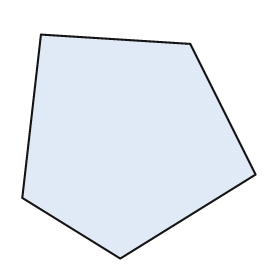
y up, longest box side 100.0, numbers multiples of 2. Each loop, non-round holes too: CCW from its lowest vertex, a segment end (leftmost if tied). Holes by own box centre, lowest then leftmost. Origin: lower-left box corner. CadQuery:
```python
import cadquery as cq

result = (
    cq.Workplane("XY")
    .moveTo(42.0, 0.0)
    .lineTo(100.0, 36.0)
    .lineTo(72.0, 92.0)
    .lineTo(8.0, 96.0)
    .lineTo(0.0, 26.0)
    .close()
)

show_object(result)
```